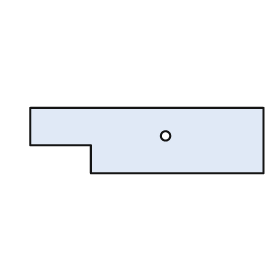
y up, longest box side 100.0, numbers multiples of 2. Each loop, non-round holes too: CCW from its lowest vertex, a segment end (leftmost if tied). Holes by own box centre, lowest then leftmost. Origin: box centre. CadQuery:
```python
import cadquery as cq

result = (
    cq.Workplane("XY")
    .moveTo(-24.0, -14.0)
    .lineTo(50.0, -14.0)
    .lineTo(50.0, 14.0)
    .lineTo(-50.0, 14.0)
    .lineTo(-50.0, -2.0)
    .lineTo(-24.0, -2.0)
    .close()
    .moveTo(8.0, 2.0)
    .circle(2.0)
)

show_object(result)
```